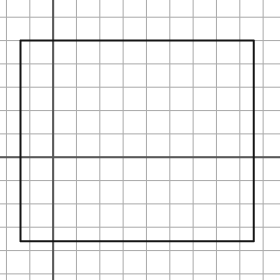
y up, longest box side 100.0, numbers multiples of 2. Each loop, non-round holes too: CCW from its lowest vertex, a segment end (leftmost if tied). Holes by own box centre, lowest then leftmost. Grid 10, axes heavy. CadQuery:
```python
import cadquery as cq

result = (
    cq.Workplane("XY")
    .moveTo(-14.0, -36.0)
    .lineTo(86.0, -36.0)
    .lineTo(86.0, 50.0)
    .lineTo(-14.0, 50.0)
    .close()
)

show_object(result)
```